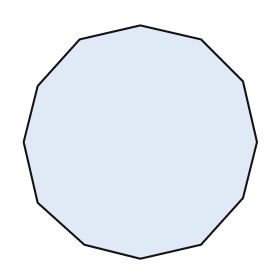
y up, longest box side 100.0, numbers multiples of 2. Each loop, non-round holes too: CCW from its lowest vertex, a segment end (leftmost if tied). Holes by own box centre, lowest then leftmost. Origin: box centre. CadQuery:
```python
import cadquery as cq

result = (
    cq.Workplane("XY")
    .moveTo(0.0, -50.0)
    .lineTo(26.0, -44.0)
    .lineTo(44.0, -24.0)
    .lineTo(50.0, 0.0)
    .lineTo(44.0, 26.0)
    .lineTo(26.0, 44.0)
    .lineTo(0.0, 50.0)
    .lineTo(-26.0, 44.0)
    .lineTo(-44.0, 24.0)
    .lineTo(-50.0, 0.0)
    .lineTo(-44.0, -26.0)
    .lineTo(-24.0, -44.0)
    .close()
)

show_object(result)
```